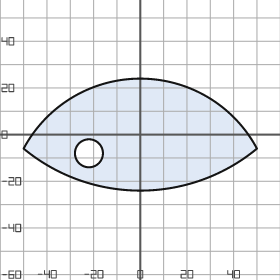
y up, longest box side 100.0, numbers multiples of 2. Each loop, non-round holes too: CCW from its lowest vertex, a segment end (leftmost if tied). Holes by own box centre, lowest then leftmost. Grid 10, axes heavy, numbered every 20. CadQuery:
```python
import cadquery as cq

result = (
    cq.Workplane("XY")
    .moveTo(-50.0, -6.0)
    .threePointArc((0.0, -24.0), (50.0, -6.0))
    .threePointArc((0.0, 24.0), (-50.0, -6.0))
    .close()
    .moveTo(-22.0, -8.0)
    .circle(6.0)
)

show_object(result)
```